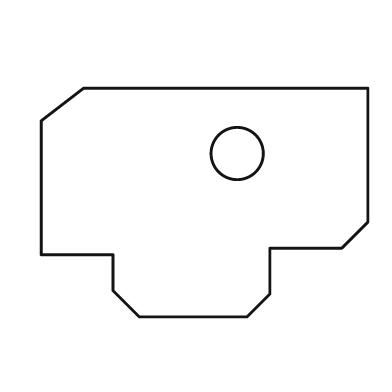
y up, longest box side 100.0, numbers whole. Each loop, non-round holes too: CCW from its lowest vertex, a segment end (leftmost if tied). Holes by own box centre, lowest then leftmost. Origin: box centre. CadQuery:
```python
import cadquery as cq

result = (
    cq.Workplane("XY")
    .moveTo(-20.0, -35.0)
    .lineTo(13.0, -35.0)
    .lineTo(20.0, -28.0)
    .lineTo(20.0, -14.0)
    .lineTo(42.0, -14.0)
    .lineTo(50.0, -6.0)
    .lineTo(50.0, 35.0)
    .lineTo(-37.0, 35.0)
    .lineTo(-50.0, 25.0)
    .lineTo(-50.0, -16.0)
    .lineTo(-28.0, -16.0)
    .lineTo(-28.0, -27.0)
    .close()
    .moveTo(10.0, 15.0)
    .circle(8.0)
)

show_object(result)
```